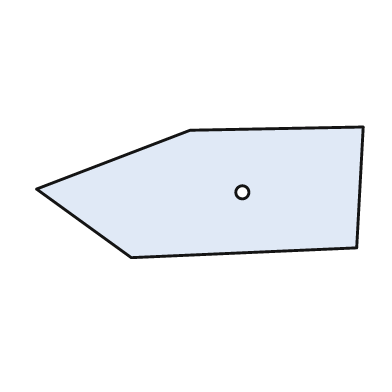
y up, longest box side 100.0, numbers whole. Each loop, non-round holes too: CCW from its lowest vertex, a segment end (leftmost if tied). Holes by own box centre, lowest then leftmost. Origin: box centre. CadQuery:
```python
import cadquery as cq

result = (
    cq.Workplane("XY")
    .moveTo(-21.0, -20.0)
    .lineTo(48.0, -17.0)
    .lineTo(50.0, 20.0)
    .lineTo(-3.0, 19.0)
    .lineTo(-50.0, 1.0)
    .close()
    .moveTo(13.0, 0.0)
    .circle(2.0)
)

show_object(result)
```